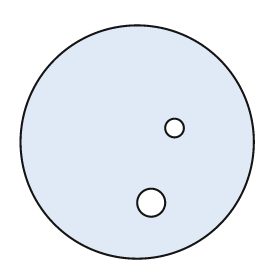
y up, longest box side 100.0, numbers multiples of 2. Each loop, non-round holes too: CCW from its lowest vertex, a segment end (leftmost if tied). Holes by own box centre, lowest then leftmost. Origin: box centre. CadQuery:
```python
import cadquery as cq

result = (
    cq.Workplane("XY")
    .moveTo(0.0, 0.0)
    .circle(50.0)
    .moveTo(6.0, -26.0)
    .circle(6.0)
    .moveTo(16.0, 6.0)
    .circle(4.0)
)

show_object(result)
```